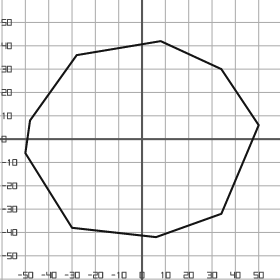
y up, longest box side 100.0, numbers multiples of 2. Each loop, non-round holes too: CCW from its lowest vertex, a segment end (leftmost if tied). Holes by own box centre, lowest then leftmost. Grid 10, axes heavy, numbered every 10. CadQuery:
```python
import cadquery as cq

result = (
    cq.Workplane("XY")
    .moveTo(6.0, -42.0)
    .lineTo(34.0, -32.0)
    .lineTo(50.0, 6.0)
    .lineTo(34.0, 30.0)
    .lineTo(8.0, 42.0)
    .lineTo(-28.0, 36.0)
    .lineTo(-48.0, 8.0)
    .lineTo(-50.0, -6.0)
    .lineTo(-30.0, -38.0)
    .close()
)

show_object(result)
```